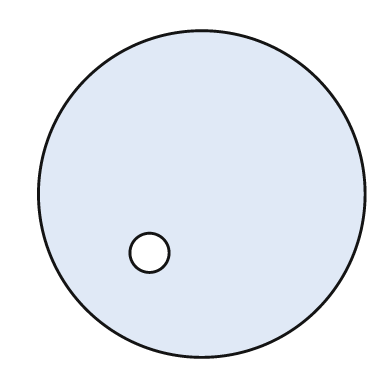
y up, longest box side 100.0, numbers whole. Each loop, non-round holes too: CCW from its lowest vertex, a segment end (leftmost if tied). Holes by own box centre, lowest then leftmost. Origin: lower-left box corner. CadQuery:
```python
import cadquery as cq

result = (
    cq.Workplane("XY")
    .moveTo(50.0, 50.0)
    .circle(50.0)
    .moveTo(34.0, 32.0)
    .circle(6.0)
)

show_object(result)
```